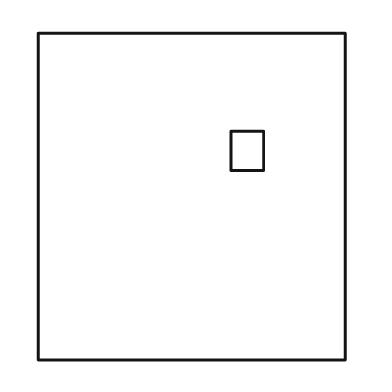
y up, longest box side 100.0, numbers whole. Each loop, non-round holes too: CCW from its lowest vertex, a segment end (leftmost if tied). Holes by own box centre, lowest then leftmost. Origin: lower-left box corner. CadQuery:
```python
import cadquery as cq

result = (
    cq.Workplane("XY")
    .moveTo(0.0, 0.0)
    .lineTo(94.0, 0.0)
    .lineTo(94.0, 100.0)
    .lineTo(0.0, 100.0)
    .close()
    .moveTo(59.0, 58.0)
    .lineTo(69.0, 58.0)
    .lineTo(69.0, 70.0)
    .lineTo(59.0, 70.0)
    .close()
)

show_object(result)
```